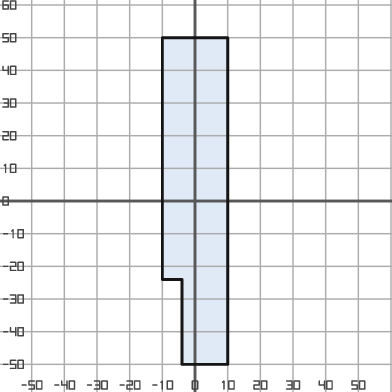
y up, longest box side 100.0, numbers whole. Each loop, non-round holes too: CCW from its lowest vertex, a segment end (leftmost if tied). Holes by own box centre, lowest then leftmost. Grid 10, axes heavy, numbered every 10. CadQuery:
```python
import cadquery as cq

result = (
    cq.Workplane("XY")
    .moveTo(-4.0, -50.0)
    .lineTo(10.0, -50.0)
    .lineTo(10.0, 50.0)
    .lineTo(-10.0, 50.0)
    .lineTo(-10.0, -24.0)
    .lineTo(-4.0, -24.0)
    .close()
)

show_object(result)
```